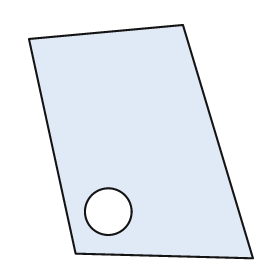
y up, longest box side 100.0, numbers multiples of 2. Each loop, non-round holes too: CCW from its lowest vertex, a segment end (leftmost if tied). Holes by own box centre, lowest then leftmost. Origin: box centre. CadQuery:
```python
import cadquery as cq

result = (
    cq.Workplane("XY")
    .moveTo(48.0, -50.0)
    .lineTo(18.0, 50.0)
    .lineTo(-48.0, 44.0)
    .lineTo(-28.0, -48.0)
    .close()
    .moveTo(-14.0, -30.0)
    .circle(10.0)
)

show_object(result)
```